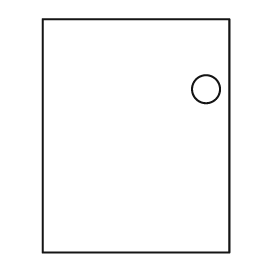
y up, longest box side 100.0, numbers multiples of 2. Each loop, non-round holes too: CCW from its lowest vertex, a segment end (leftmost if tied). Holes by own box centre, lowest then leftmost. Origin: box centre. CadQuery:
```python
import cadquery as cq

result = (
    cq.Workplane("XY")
    .moveTo(-40.0, -50.0)
    .lineTo(40.0, -50.0)
    .lineTo(40.0, 50.0)
    .lineTo(-40.0, 50.0)
    .close()
    .moveTo(30.0, 20.0)
    .circle(6.0)
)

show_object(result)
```